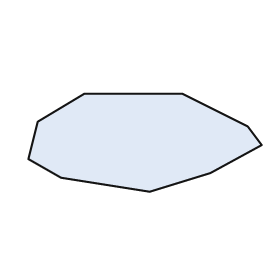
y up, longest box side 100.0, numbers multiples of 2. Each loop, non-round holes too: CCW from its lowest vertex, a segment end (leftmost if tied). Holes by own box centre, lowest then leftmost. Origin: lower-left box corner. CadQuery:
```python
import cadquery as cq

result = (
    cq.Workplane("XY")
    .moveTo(52.0, 0.0)
    .lineTo(78.0, 8.0)
    .lineTo(100.0, 20.0)
    .lineTo(94.0, 28.0)
    .lineTo(66.0, 42.0)
    .lineTo(24.0, 42.0)
    .lineTo(4.0, 30.0)
    .lineTo(0.0, 14.0)
    .lineTo(14.0, 6.0)
    .close()
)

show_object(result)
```